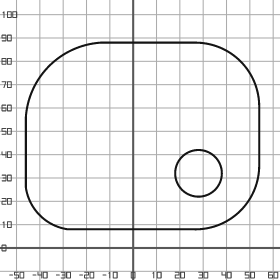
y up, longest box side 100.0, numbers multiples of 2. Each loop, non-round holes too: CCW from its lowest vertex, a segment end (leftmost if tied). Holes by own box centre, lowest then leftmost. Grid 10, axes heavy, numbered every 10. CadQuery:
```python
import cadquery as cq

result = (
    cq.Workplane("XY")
    .moveTo(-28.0, 8.0)
    .lineTo(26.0, 8.0)
    .threePointArc((46.0, 16.0), (54.0, 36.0))
    .lineTo(54.0, 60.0)
    .threePointArc((46.0, 80.0), (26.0, 88.0))
    .lineTo(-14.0, 88.0)
    .threePointArc((-36.0, 78.0), (-46.0, 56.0))
    .lineTo(-46.0, 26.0)
    .threePointArc((-40.0, 14.0), (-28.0, 8.0))
    .close()
    .moveTo(28.0, 32.0)
    .circle(10.0)
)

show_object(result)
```